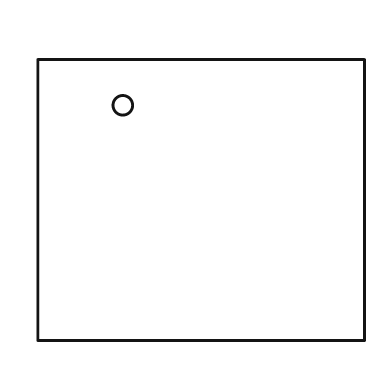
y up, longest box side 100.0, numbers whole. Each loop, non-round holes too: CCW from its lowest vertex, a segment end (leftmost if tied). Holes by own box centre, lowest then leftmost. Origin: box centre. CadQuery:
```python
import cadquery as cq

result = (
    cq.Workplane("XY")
    .moveTo(-50.0, -43.0)
    .lineTo(50.0, -43.0)
    .lineTo(50.0, 43.0)
    .lineTo(-50.0, 43.0)
    .close()
    .moveTo(-24.0, 29.0)
    .circle(3.0)
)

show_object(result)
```